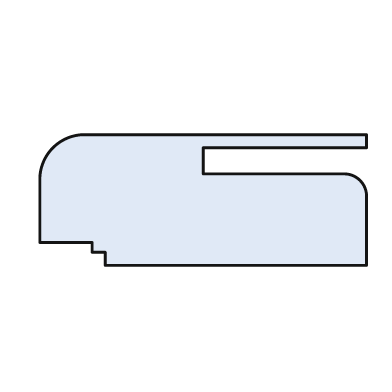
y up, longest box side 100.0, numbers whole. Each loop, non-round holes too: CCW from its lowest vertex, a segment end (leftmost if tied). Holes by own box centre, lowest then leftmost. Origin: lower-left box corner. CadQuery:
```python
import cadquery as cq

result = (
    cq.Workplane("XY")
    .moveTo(20.0, 0.0)
    .lineTo(100.0, 0.0)
    .lineTo(100.0, 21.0)
    .threePointArc((98.0, 26.0), (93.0, 28.0))
    .lineTo(50.0, 28.0)
    .lineTo(50.0, 36.0)
    .lineTo(100.0, 36.0)
    .lineTo(100.0, 40.0)
    .lineTo(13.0, 40.0)
    .threePointArc((4.0, 36.0), (0.0, 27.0))
    .lineTo(0.0, 7.0)
    .lineTo(16.0, 7.0)
    .lineTo(16.0, 4.0)
    .lineTo(20.0, 4.0)
    .close()
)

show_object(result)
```